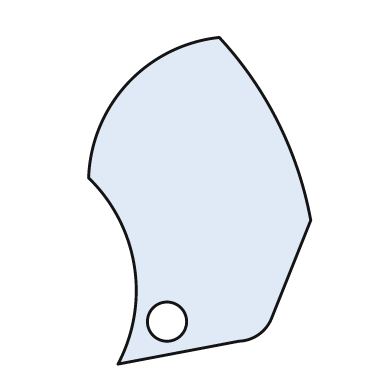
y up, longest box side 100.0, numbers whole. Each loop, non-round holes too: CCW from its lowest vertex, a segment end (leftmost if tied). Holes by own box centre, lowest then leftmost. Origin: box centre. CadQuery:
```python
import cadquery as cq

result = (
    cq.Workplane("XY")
    .moveTo(-25.0, -50.0)
    .lineTo(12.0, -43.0)
    .threePointArc((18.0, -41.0), (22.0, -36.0))
    .lineTo(34.0, -6.0)
    .threePointArc((24.0, 24.0), (6.0, 50.0))
    .threePointArc((-22.0, 36.0), (-34.0, 7.0))
    .threePointArc((-20.0, -20.0), (-25.0, -50.0))
    .close()
    .moveTo(-10.0, -37.0)
    .circle(6.0)
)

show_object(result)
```